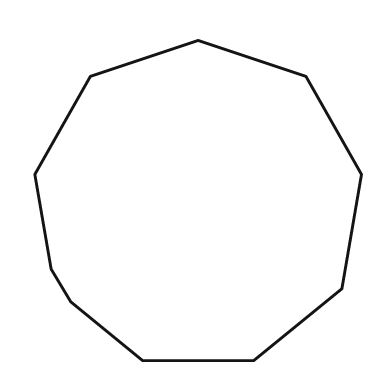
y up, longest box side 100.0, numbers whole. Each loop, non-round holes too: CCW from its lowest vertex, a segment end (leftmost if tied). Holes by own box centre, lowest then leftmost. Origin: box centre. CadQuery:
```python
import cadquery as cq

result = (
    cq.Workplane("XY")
    .moveTo(-17.0, -49.0)
    .lineTo(17.0, -49.0)
    .lineTo(44.0, -27.0)
    .lineTo(50.0, 8.0)
    .lineTo(33.0, 38.0)
    .lineTo(0.0, 49.0)
    .lineTo(-33.0, 38.0)
    .lineTo(-50.0, 8.0)
    .lineTo(-45.0, -21.0)
    .lineTo(-39.0, -31.0)
    .close()
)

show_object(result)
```